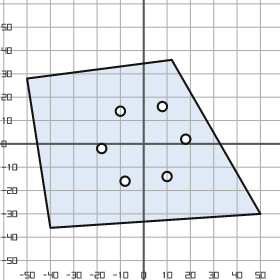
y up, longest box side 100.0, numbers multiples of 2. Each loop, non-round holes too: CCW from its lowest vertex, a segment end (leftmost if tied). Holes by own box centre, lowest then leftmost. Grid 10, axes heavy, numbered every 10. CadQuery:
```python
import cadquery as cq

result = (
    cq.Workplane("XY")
    .moveTo(-40.0, -36.0)
    .lineTo(50.0, -30.0)
    .lineTo(12.0, 36.0)
    .lineTo(-50.0, 28.0)
    .close()
    .moveTo(-8.0, -16.0)
    .circle(2.0)
    .moveTo(10.0, -14.0)
    .circle(2.0)
    .moveTo(-18.0, -2.0)
    .circle(2.0)
    .moveTo(18.0, 2.0)
    .circle(2.0)
    .moveTo(-10.0, 14.0)
    .circle(2.0)
    .moveTo(8.0, 16.0)
    .circle(2.0)
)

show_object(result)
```